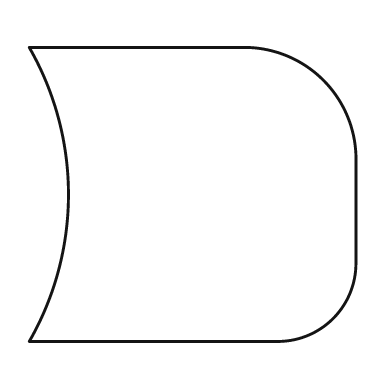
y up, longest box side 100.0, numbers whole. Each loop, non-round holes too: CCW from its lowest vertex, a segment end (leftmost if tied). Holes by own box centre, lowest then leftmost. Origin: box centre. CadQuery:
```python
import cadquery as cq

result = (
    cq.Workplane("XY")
    .moveTo(-50.0, -45.0)
    .lineTo(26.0, -45.0)
    .threePointArc((43.0, -38.0), (50.0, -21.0))
    .lineTo(50.0, 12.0)
    .threePointArc((40.0, 35.0), (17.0, 45.0))
    .lineTo(-50.0, 45.0)
    .threePointArc((-38.0, 0.0), (-50.0, -45.0))
    .close()
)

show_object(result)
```